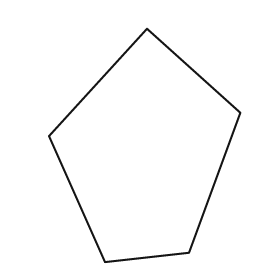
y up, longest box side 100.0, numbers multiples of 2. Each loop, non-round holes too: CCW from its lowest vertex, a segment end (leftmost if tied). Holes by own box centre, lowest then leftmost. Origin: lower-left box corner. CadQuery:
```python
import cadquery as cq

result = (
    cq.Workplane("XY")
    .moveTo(24.0, 0.0)
    .lineTo(60.0, 4.0)
    .lineTo(82.0, 64.0)
    .lineTo(42.0, 100.0)
    .lineTo(0.0, 54.0)
    .close()
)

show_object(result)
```